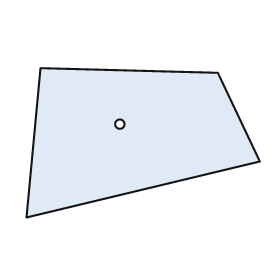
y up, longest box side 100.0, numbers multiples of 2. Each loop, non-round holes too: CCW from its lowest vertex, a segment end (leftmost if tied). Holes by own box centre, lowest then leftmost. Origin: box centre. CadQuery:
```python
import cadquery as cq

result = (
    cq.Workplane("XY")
    .moveTo(-50.0, -32.0)
    .lineTo(50.0, -8.0)
    .lineTo(32.0, 30.0)
    .lineTo(-44.0, 32.0)
    .close()
    .moveTo(-10.0, 8.0)
    .circle(2.0)
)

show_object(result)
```